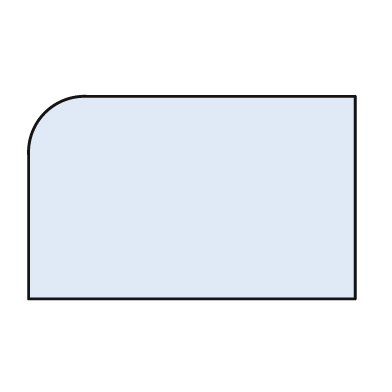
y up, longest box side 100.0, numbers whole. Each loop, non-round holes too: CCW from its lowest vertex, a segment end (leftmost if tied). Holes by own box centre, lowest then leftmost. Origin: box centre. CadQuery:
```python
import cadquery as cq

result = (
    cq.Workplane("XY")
    .moveTo(-50.0, -31.0)
    .lineTo(50.0, -31.0)
    .lineTo(50.0, 31.0)
    .lineTo(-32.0, 31.0)
    .threePointArc((-45.0, 26.0), (-50.0, 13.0))
    .close()
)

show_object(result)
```